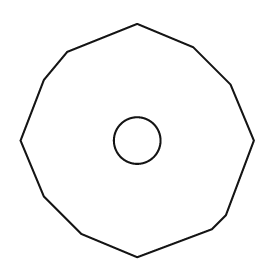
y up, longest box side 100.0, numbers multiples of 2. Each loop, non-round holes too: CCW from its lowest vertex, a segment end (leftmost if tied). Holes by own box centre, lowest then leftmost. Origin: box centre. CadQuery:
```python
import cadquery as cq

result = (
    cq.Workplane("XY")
    .moveTo(0.0, -50.0)
    .lineTo(32.0, -38.0)
    .lineTo(38.0, -32.0)
    .lineTo(50.0, 0.0)
    .lineTo(40.0, 24.0)
    .lineTo(24.0, 40.0)
    .lineTo(0.0, 50.0)
    .lineTo(-30.0, 38.0)
    .lineTo(-40.0, 26.0)
    .lineTo(-50.0, 0.0)
    .lineTo(-40.0, -24.0)
    .lineTo(-24.0, -40.0)
    .close()
    .moveTo(0.0, 0.0)
    .circle(10.0)
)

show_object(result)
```